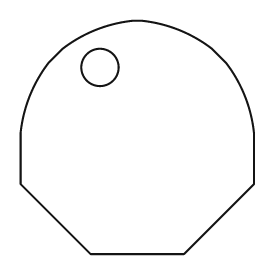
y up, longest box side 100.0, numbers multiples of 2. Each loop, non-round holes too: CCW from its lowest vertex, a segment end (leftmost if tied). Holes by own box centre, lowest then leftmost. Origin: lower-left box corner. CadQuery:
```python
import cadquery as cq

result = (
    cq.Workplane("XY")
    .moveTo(30.0, 0.0)
    .lineTo(70.0, 0.0)
    .lineTo(100.0, 30.0)
    .lineTo(100.0, 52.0)
    .threePointArc((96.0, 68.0), (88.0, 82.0))
    .lineTo(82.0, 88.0)
    .threePointArc((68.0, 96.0), (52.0, 100.0))
    .lineTo(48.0, 100.0)
    .threePointArc((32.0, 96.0), (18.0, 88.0))
    .lineTo(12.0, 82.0)
    .threePointArc((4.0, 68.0), (0.0, 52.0))
    .lineTo(0.0, 30.0)
    .close()
    .moveTo(34.0, 80.0)
    .circle(8.0)
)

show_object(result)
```